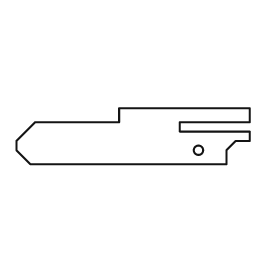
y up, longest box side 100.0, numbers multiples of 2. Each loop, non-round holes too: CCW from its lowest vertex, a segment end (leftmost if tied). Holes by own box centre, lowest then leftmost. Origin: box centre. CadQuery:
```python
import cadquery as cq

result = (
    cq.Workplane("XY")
    .moveTo(-44.0, -12.0)
    .lineTo(40.0, -12.0)
    .lineTo(40.0, -6.0)
    .lineTo(44.0, -2.0)
    .lineTo(50.0, -2.0)
    .lineTo(50.0, 2.0)
    .lineTo(20.0, 2.0)
    .lineTo(20.0, 6.0)
    .lineTo(50.0, 6.0)
    .lineTo(50.0, 12.0)
    .lineTo(-6.0, 12.0)
    .lineTo(-6.0, 6.0)
    .lineTo(-42.0, 6.0)
    .lineTo(-50.0, -2.0)
    .lineTo(-50.0, -6.0)
    .close()
    .moveTo(28.0, -6.0)
    .circle(2.0)
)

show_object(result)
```